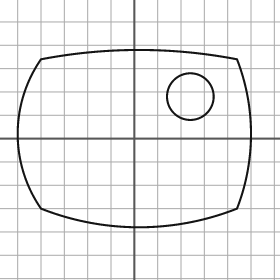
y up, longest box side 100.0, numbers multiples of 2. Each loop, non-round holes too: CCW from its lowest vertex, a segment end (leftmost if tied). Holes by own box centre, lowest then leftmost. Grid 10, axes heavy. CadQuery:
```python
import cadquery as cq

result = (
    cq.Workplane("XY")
    .moveTo(-40.0, -30.0)
    .threePointArc((2.0, -38.0), (44.0, -30.0))
    .threePointArc((50.0, 2.0), (44.0, 34.0))
    .threePointArc((2.0, 38.0), (-40.0, 34.0))
    .threePointArc((-50.0, 2.0), (-40.0, -30.0))
    .close()
    .moveTo(24.0, 18.0)
    .circle(10.0)
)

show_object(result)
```